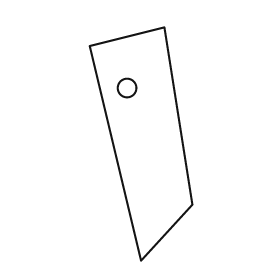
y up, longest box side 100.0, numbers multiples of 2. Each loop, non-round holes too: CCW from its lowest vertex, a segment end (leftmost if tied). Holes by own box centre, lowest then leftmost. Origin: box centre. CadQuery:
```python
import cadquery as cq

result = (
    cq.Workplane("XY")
    .moveTo(0.0, -50.0)
    .lineTo(22.0, -26.0)
    .lineTo(10.0, 50.0)
    .lineTo(-22.0, 42.0)
    .close()
    .moveTo(-6.0, 24.0)
    .circle(4.0)
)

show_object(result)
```